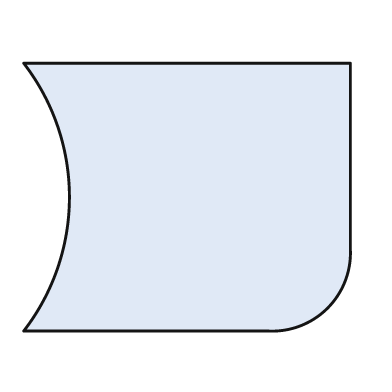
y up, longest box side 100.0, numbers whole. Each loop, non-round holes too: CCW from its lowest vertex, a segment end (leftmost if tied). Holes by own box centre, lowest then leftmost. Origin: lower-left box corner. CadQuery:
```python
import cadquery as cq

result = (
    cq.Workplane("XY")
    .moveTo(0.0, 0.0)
    .lineTo(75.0, 0.0)
    .threePointArc((93.0, 7.0), (100.0, 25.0))
    .lineTo(100.0, 82.0)
    .lineTo(0.0, 82.0)
    .threePointArc((14.0, 41.0), (0.0, 0.0))
    .close()
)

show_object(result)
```